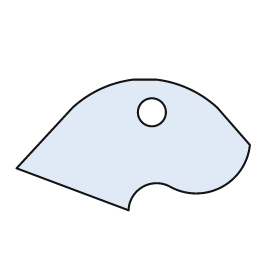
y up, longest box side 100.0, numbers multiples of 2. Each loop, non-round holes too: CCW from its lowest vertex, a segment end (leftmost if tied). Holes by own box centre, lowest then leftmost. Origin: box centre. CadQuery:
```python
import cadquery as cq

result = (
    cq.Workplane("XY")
    .moveTo(-2.0, -28.0)
    .threePointArc((4.0, -18.0), (16.0, -18.0))
    .threePointArc((38.0, -18.0), (50.0, 0.0))
    .lineTo(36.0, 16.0)
    .threePointArc((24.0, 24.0), (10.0, 28.0))
    .lineTo(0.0, 28.0)
    .threePointArc((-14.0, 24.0), (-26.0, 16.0))
    .lineTo(-50.0, -10.0)
    .close()
    .moveTo(8.0, 14.0)
    .circle(6.0)
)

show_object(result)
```